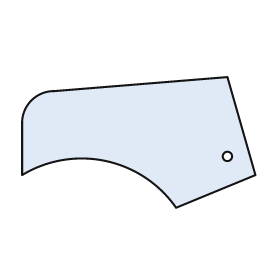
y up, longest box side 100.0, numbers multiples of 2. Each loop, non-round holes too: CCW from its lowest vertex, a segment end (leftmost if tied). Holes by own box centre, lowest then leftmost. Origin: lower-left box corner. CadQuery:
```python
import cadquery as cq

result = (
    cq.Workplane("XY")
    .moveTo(66.0, 0.0)
    .lineTo(100.0, 14.0)
    .lineTo(88.0, 56.0)
    .lineTo(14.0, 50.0)
    .threePointArc((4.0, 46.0), (0.0, 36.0))
    .lineTo(0.0, 14.0)
    .threePointArc((36.0, 20.0), (66.0, 0.0))
    .close()
    .moveTo(88.0, 22.0)
    .circle(2.0)
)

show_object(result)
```